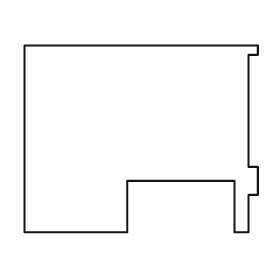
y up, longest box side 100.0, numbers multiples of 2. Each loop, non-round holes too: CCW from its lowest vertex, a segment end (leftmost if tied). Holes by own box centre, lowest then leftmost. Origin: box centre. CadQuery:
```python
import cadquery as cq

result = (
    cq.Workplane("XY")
    .moveTo(-50.0, -40.0)
    .lineTo(-6.0, -40.0)
    .lineTo(-6.0, -18.0)
    .lineTo(40.0, -18.0)
    .lineTo(40.0, -40.0)
    .lineTo(46.0, -40.0)
    .lineTo(46.0, -24.0)
    .lineTo(50.0, -24.0)
    .lineTo(50.0, -12.0)
    .lineTo(46.0, -12.0)
    .lineTo(46.0, 36.0)
    .lineTo(50.0, 36.0)
    .lineTo(50.0, 40.0)
    .lineTo(-50.0, 40.0)
    .close()
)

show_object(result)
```